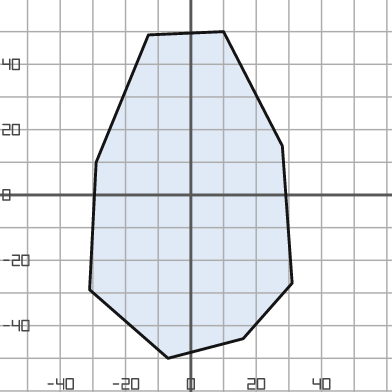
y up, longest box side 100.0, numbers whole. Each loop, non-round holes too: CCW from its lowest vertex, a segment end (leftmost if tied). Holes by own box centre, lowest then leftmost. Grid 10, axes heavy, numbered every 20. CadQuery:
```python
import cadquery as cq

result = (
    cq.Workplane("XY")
    .moveTo(-7.0, -50.0)
    .lineTo(16.0, -44.0)
    .lineTo(31.0, -27.0)
    .lineTo(28.0, 15.0)
    .lineTo(10.0, 50.0)
    .lineTo(-13.0, 49.0)
    .lineTo(-29.0, 10.0)
    .lineTo(-31.0, -29.0)
    .close()
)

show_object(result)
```